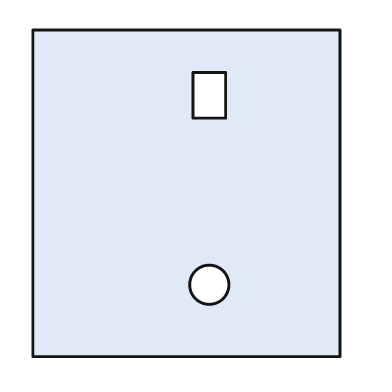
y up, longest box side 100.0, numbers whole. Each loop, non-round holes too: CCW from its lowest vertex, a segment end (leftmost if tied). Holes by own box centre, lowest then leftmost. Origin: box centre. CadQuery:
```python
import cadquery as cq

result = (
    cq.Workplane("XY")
    .moveTo(-47.0, -50.0)
    .lineTo(47.0, -50.0)
    .lineTo(47.0, 50.0)
    .lineTo(-47.0, 50.0)
    .close()
    .moveTo(7.0, -28.0)
    .circle(6.0)
    .moveTo(2.0, 23.0)
    .lineTo(12.0, 23.0)
    .lineTo(12.0, 37.0)
    .lineTo(2.0, 37.0)
    .close()
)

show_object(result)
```